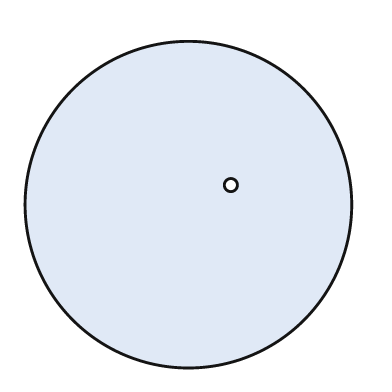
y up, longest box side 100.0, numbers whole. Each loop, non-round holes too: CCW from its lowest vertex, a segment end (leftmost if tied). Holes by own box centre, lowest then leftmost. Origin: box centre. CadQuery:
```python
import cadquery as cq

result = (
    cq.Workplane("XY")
    .moveTo(0.0, 0.0)
    .circle(50.0)
    .moveTo(13.0, 6.0)
    .circle(2.0)
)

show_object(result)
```